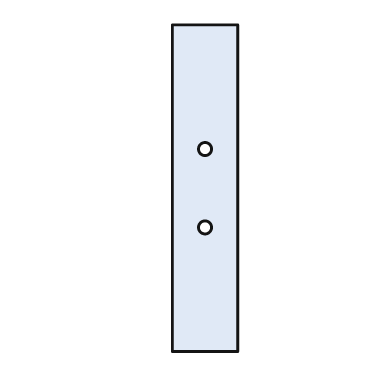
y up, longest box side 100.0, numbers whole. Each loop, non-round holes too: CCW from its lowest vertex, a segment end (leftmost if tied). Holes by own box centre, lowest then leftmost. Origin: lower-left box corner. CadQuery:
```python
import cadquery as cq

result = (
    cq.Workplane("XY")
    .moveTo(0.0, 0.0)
    .lineTo(20.0, 0.0)
    .lineTo(20.0, 100.0)
    .lineTo(0.0, 100.0)
    .close()
    .moveTo(10.0, 38.0)
    .circle(2.0)
    .moveTo(10.0, 62.0)
    .circle(2.0)
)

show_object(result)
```